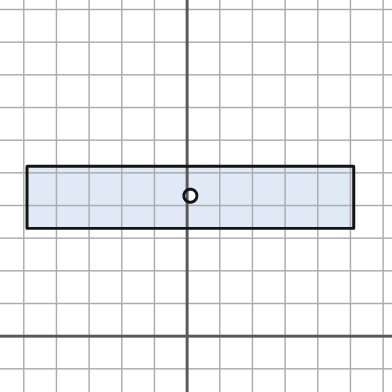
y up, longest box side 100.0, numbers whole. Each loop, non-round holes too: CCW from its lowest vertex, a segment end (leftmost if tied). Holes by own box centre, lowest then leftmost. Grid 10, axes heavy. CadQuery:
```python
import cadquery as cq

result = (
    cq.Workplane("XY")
    .moveTo(-49.0, 33.0)
    .lineTo(51.0, 33.0)
    .lineTo(51.0, 52.0)
    .lineTo(-49.0, 52.0)
    .close()
    .moveTo(1.0, 43.0)
    .circle(2.0)
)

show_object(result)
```